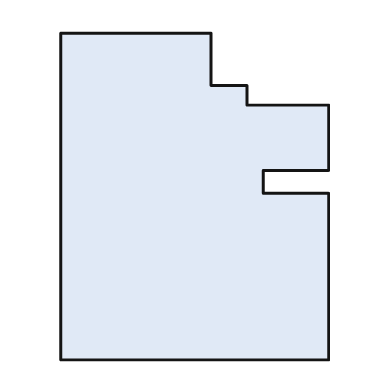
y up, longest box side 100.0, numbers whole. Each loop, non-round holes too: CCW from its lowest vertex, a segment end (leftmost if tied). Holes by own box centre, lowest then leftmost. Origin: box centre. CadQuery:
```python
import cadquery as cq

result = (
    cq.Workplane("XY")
    .moveTo(-41.0, -50.0)
    .lineTo(41.0, -50.0)
    .lineTo(41.0, 1.0)
    .lineTo(21.0, 1.0)
    .lineTo(21.0, 8.0)
    .lineTo(41.0, 8.0)
    .lineTo(41.0, 28.0)
    .lineTo(16.0, 28.0)
    .lineTo(16.0, 34.0)
    .lineTo(5.0, 34.0)
    .lineTo(5.0, 50.0)
    .lineTo(-41.0, 50.0)
    .close()
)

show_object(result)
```